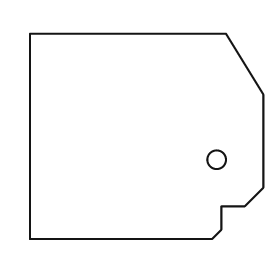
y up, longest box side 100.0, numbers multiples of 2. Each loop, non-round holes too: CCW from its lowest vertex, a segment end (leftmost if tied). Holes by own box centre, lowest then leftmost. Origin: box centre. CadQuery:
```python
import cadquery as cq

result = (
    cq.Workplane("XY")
    .moveTo(-50.0, -44.0)
    .lineTo(28.0, -44.0)
    .lineTo(32.0, -40.0)
    .lineTo(32.0, -30.0)
    .lineTo(42.0, -30.0)
    .lineTo(50.0, -22.0)
    .lineTo(50.0, 18.0)
    .lineTo(34.0, 44.0)
    .lineTo(-50.0, 44.0)
    .close()
    .moveTo(30.0, -10.0)
    .circle(4.0)
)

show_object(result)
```